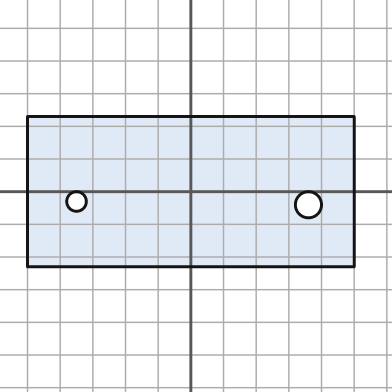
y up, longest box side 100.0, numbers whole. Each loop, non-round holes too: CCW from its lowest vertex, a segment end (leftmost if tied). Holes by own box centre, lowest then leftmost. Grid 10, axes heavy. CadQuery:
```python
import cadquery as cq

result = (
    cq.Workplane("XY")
    .moveTo(-50.0, -23.0)
    .lineTo(50.0, -23.0)
    .lineTo(50.0, 23.0)
    .lineTo(-50.0, 23.0)
    .close()
    .moveTo(36.0, -4.0)
    .circle(4.0)
    .moveTo(-35.0, -3.0)
    .circle(3.0)
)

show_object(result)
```